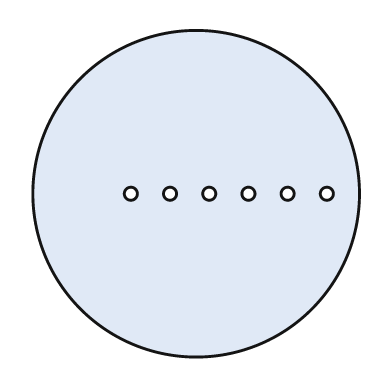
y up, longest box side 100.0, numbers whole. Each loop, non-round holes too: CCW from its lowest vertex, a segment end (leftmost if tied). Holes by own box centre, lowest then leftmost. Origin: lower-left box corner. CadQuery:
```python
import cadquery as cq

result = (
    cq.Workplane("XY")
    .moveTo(50.0, 50.0)
    .circle(50.0)
    .moveTo(30.0, 50.0)
    .circle(2.0)
    .moveTo(42.0, 50.0)
    .circle(2.0)
    .moveTo(54.0, 50.0)
    .circle(2.0)
    .moveTo(66.0, 50.0)
    .circle(2.0)
    .moveTo(78.0, 50.0)
    .circle(2.0)
    .moveTo(90.0, 50.0)
    .circle(2.0)
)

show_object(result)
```